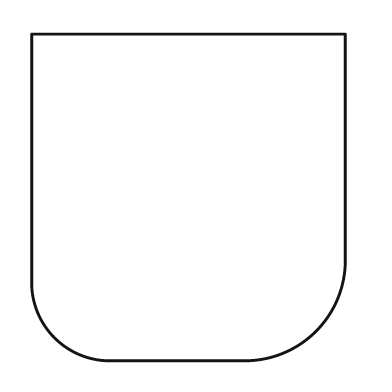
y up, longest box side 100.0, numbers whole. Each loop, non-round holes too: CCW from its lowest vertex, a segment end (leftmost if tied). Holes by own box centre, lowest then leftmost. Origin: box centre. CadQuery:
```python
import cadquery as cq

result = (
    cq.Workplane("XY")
    .moveTo(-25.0, -50.0)
    .lineTo(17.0, -50.0)
    .threePointArc((39.0, -41.0), (48.0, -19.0))
    .lineTo(48.0, 50.0)
    .lineTo(-48.0, 50.0)
    .lineTo(-48.0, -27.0)
    .threePointArc((-41.0, -43.0), (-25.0, -50.0))
    .close()
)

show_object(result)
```